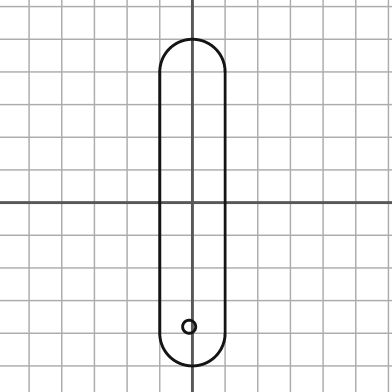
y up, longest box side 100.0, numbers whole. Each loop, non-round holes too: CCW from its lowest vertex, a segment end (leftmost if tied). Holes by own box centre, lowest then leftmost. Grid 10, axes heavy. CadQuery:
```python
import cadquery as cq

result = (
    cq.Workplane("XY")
    .moveTo(-10.0, -40.0)
    .threePointArc((0.0, -50.0), (10.0, -40.0))
    .lineTo(10.0, 40.0)
    .threePointArc((0.0, 50.0), (-10.0, 40.0))
    .close()
    .moveTo(-1.0, -38.0)
    .circle(2.0)
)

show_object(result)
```